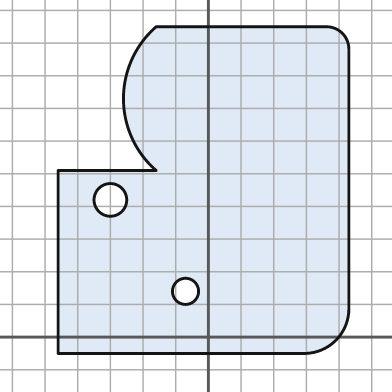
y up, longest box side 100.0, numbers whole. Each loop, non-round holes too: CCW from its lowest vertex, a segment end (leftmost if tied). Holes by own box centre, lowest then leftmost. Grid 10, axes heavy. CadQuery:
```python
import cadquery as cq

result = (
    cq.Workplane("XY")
    .moveTo(-46.0, -5.0)
    .lineTo(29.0, -5.0)
    .threePointArc((39.0, -1.0), (43.0, 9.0))
    .lineTo(43.0, 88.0)
    .threePointArc((41.0, 93.0), (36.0, 95.0))
    .lineTo(-16.0, 95.0)
    .threePointArc((-26.0, 73.0), (-16.0, 51.0))
    .lineTo(-46.0, 51.0)
    .close()
    .moveTo(-7.0, 14.0)
    .circle(4.0)
    .moveTo(-30.0, 42.0)
    .circle(5.0)
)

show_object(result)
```